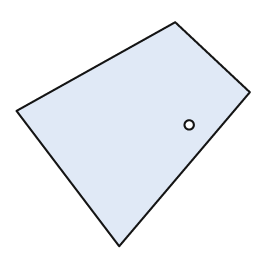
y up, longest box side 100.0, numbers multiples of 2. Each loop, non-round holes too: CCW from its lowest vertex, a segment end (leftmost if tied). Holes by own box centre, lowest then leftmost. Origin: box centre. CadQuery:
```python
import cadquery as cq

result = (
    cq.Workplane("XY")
    .moveTo(-6.0, -48.0)
    .lineTo(50.0, 18.0)
    .lineTo(18.0, 48.0)
    .lineTo(-50.0, 10.0)
    .close()
    .moveTo(24.0, 4.0)
    .circle(2.0)
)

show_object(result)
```